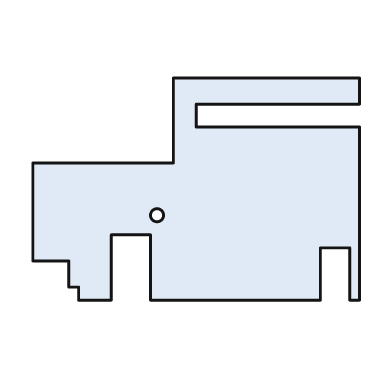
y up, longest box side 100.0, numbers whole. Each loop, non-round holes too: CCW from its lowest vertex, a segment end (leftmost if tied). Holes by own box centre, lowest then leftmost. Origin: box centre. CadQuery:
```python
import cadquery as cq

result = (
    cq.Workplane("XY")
    .moveTo(-36.0, -34.0)
    .lineTo(-26.0, -34.0)
    .lineTo(-26.0, -14.0)
    .lineTo(-14.0, -14.0)
    .lineTo(-14.0, -34.0)
    .lineTo(38.0, -34.0)
    .lineTo(38.0, -18.0)
    .lineTo(47.0, -18.0)
    .lineTo(47.0, -34.0)
    .lineTo(50.0, -34.0)
    .lineTo(50.0, 19.0)
    .lineTo(0.0, 19.0)
    .lineTo(0.0, 26.0)
    .lineTo(50.0, 26.0)
    .lineTo(50.0, 34.0)
    .lineTo(-7.0, 34.0)
    .lineTo(-7.0, 8.0)
    .lineTo(-50.0, 8.0)
    .lineTo(-50.0, -22.0)
    .lineTo(-39.0, -22.0)
    .lineTo(-39.0, -30.0)
    .lineTo(-36.0, -30.0)
    .close()
    .moveTo(-12.0, -8.0)
    .circle(2.0)
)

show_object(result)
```